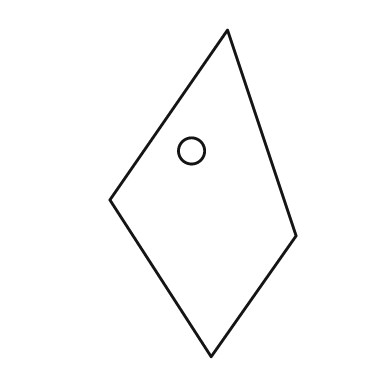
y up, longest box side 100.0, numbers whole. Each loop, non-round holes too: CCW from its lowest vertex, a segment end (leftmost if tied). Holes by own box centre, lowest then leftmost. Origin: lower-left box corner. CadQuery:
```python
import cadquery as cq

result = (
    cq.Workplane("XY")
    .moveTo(31.0, 0.0)
    .lineTo(57.0, 37.0)
    .lineTo(36.0, 100.0)
    .lineTo(0.0, 48.0)
    .close()
    .moveTo(25.0, 63.0)
    .circle(4.0)
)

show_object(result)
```